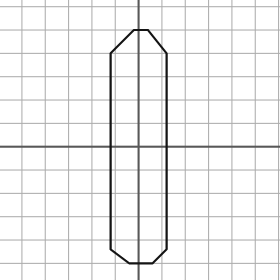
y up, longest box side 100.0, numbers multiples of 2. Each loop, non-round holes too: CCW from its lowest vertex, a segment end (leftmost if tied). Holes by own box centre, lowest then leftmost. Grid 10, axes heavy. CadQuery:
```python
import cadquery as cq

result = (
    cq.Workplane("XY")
    .moveTo(-4.0, -50.0)
    .lineTo(6.0, -50.0)
    .lineTo(12.0, -44.0)
    .lineTo(12.0, 40.0)
    .lineTo(4.0, 50.0)
    .lineTo(-2.0, 50.0)
    .lineTo(-12.0, 40.0)
    .lineTo(-12.0, -44.0)
    .close()
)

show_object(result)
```